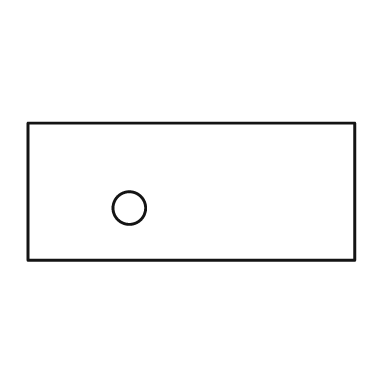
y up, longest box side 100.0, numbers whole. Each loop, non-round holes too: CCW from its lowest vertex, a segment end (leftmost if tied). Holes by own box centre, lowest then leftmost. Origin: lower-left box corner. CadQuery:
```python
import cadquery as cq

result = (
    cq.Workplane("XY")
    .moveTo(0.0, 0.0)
    .lineTo(100.0, 0.0)
    .lineTo(100.0, 42.0)
    .lineTo(0.0, 42.0)
    .close()
    .moveTo(31.0, 16.0)
    .circle(5.0)
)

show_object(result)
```